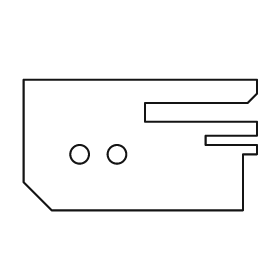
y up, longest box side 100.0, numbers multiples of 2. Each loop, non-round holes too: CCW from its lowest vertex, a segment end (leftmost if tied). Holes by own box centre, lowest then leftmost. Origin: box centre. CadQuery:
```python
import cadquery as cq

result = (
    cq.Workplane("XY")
    .moveTo(-38.0, -28.0)
    .lineTo(44.0, -28.0)
    .lineTo(44.0, -4.0)
    .lineTo(50.0, -4.0)
    .lineTo(50.0, 0.0)
    .lineTo(28.0, 0.0)
    .lineTo(28.0, 4.0)
    .lineTo(50.0, 4.0)
    .lineTo(50.0, 10.0)
    .lineTo(2.0, 10.0)
    .lineTo(2.0, 18.0)
    .lineTo(46.0, 18.0)
    .lineTo(50.0, 22.0)
    .lineTo(50.0, 28.0)
    .lineTo(-50.0, 28.0)
    .lineTo(-50.0, -16.0)
    .close()
    .moveTo(-26.0, -4.0)
    .circle(4.0)
    .moveTo(-10.0, -4.0)
    .circle(4.0)
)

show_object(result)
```